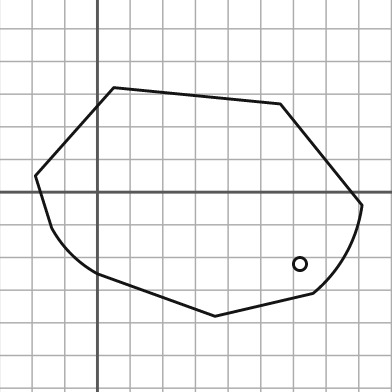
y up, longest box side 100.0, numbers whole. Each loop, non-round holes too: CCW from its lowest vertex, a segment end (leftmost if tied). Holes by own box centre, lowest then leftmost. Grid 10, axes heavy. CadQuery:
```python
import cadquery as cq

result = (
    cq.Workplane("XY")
    .moveTo(36.0, -38.0)
    .lineTo(66.0, -31.0)
    .threePointArc((76.0, -19.0), (81.0, -4.0))
    .lineTo(56.0, 27.0)
    .lineTo(5.0, 32.0)
    .lineTo(-19.0, 5.0)
    .lineTo(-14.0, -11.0)
    .threePointArc((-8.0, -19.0), (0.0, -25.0))
    .close()
    .moveTo(62.0, -22.0)
    .circle(2.0)
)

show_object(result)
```